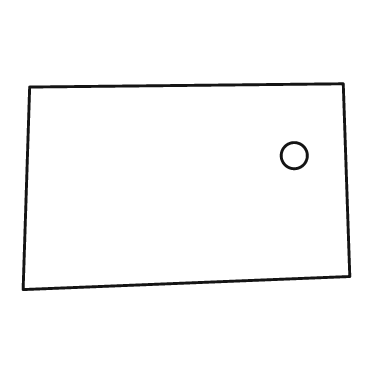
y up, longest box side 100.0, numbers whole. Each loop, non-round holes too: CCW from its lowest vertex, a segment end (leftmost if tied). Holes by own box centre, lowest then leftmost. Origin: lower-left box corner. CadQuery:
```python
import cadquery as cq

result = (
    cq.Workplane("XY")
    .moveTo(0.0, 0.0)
    .lineTo(100.0, 4.0)
    .lineTo(98.0, 63.0)
    .lineTo(2.0, 62.0)
    .close()
    .moveTo(83.0, 41.0)
    .circle(4.0)
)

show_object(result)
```